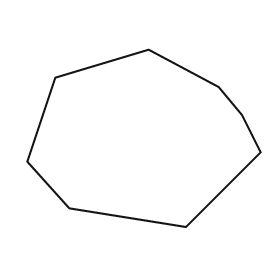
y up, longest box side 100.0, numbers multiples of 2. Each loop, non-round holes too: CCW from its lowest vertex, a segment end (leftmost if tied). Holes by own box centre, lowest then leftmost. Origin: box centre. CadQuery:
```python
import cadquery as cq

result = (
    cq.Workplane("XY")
    .moveTo(18.0, -38.0)
    .lineTo(50.0, -6.0)
    .lineTo(42.0, 10.0)
    .lineTo(32.0, 22.0)
    .lineTo(2.0, 38.0)
    .lineTo(-38.0, 26.0)
    .lineTo(-50.0, -10.0)
    .lineTo(-32.0, -30.0)
    .close()
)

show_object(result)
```